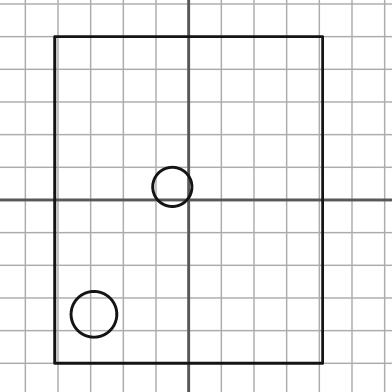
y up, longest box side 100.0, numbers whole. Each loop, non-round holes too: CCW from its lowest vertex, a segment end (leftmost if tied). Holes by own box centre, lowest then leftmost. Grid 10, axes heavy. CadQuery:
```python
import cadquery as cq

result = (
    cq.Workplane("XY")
    .moveTo(-41.0, -50.0)
    .lineTo(41.0, -50.0)
    .lineTo(41.0, 50.0)
    .lineTo(-41.0, 50.0)
    .close()
    .moveTo(-29.0, -35.0)
    .circle(7.0)
    .moveTo(-5.0, 4.0)
    .circle(6.0)
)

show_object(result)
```